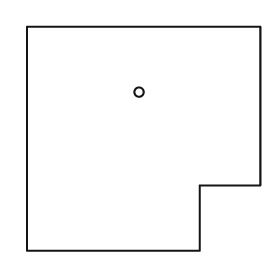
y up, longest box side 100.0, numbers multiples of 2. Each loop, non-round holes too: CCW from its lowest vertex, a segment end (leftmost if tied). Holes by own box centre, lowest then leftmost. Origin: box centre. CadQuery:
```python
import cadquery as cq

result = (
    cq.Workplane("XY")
    .moveTo(-50.0, -48.0)
    .lineTo(24.0, -48.0)
    .lineTo(24.0, -20.0)
    .lineTo(50.0, -20.0)
    .lineTo(50.0, 48.0)
    .lineTo(-50.0, 48.0)
    .close()
    .moveTo(-2.0, 20.0)
    .circle(2.0)
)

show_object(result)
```